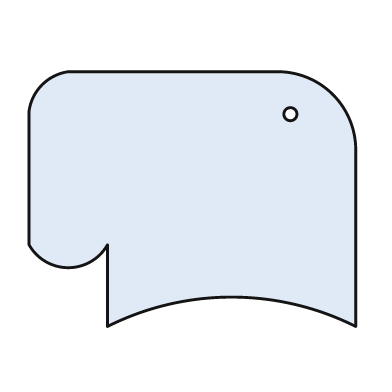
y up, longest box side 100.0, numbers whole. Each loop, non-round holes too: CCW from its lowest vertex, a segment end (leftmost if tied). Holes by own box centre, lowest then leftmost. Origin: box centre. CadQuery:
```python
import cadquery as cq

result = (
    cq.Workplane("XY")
    .moveTo(-26.0, -39.0)
    .threePointArc((12.0, -30.0), (50.0, -39.0))
    .lineTo(50.0, 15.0)
    .threePointArc((43.0, 32.0), (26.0, 39.0))
    .lineTo(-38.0, 39.0)
    .threePointArc((-46.0, 35.0), (-50.0, 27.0))
    .lineTo(-50.0, -14.0)
    .threePointArc((-38.0, -21.0), (-26.0, -14.0))
    .close()
    .moveTo(30.0, 26.0)
    .circle(2.0)
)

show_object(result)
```